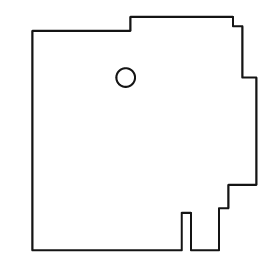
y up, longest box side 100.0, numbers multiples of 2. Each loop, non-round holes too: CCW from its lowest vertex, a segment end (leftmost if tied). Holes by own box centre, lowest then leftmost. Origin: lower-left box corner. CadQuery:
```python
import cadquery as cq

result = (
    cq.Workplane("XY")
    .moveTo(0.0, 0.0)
    .lineTo(64.0, 0.0)
    .lineTo(64.0, 16.0)
    .lineTo(68.0, 16.0)
    .lineTo(68.0, 0.0)
    .lineTo(80.0, 0.0)
    .lineTo(80.0, 18.0)
    .lineTo(84.0, 18.0)
    .lineTo(84.0, 28.0)
    .lineTo(96.0, 28.0)
    .lineTo(96.0, 74.0)
    .lineTo(90.0, 74.0)
    .lineTo(90.0, 96.0)
    .lineTo(86.0, 96.0)
    .lineTo(86.0, 100.0)
    .lineTo(42.0, 100.0)
    .lineTo(42.0, 94.0)
    .lineTo(0.0, 94.0)
    .close()
    .moveTo(40.0, 74.0)
    .circle(4.0)
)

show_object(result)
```